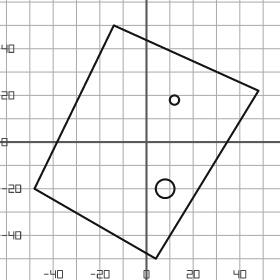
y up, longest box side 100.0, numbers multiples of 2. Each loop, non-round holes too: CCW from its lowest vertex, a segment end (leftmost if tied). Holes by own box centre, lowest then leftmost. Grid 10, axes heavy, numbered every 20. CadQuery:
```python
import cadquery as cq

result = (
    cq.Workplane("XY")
    .moveTo(4.0, -50.0)
    .lineTo(48.0, 22.0)
    .lineTo(-14.0, 50.0)
    .lineTo(-48.0, -20.0)
    .close()
    .moveTo(8.0, -20.0)
    .circle(4.0)
    .moveTo(12.0, 18.0)
    .circle(2.0)
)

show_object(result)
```